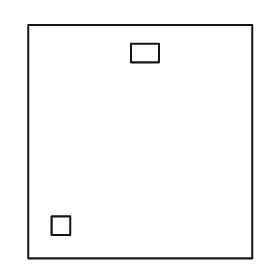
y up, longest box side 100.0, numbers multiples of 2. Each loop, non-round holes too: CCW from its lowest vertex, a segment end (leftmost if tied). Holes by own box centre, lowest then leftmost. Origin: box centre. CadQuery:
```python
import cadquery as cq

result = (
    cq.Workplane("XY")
    .moveTo(-48.0, -50.0)
    .lineTo(48.0, -50.0)
    .lineTo(48.0, 50.0)
    .lineTo(-48.0, 50.0)
    .close()
    .moveTo(-38.0, -40.0)
    .lineTo(-30.0, -40.0)
    .lineTo(-30.0, -32.0)
    .lineTo(-38.0, -32.0)
    .close()
    .moveTo(-4.0, 34.0)
    .lineTo(8.0, 34.0)
    .lineTo(8.0, 42.0)
    .lineTo(-4.0, 42.0)
    .close()
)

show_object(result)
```